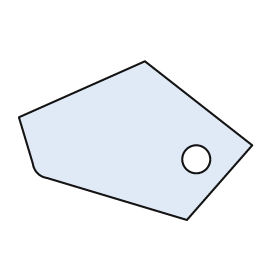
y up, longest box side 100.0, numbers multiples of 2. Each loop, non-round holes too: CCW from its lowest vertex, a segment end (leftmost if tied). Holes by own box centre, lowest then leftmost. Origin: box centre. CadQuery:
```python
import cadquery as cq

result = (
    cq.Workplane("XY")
    .moveTo(22.0, -34.0)
    .lineTo(50.0, -2.0)
    .lineTo(4.0, 34.0)
    .lineTo(-50.0, 10.0)
    .lineTo(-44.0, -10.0)
    .threePointArc((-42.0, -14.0), (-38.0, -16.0))
    .close()
    .moveTo(26.0, -8.0)
    .circle(6.0)
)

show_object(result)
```